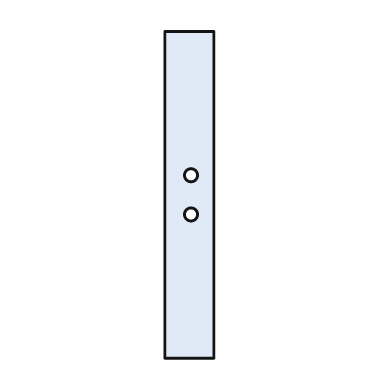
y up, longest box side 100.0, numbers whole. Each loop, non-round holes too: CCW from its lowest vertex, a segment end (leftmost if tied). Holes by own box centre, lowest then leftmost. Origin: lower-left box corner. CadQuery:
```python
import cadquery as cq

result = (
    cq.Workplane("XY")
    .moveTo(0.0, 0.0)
    .lineTo(15.0, 0.0)
    .lineTo(15.0, 100.0)
    .lineTo(0.0, 100.0)
    .close()
    .moveTo(8.0, 44.0)
    .circle(2.0)
    .moveTo(8.0, 56.0)
    .circle(2.0)
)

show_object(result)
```